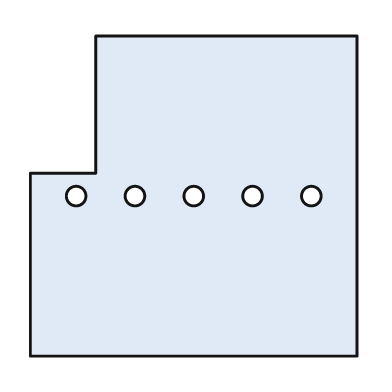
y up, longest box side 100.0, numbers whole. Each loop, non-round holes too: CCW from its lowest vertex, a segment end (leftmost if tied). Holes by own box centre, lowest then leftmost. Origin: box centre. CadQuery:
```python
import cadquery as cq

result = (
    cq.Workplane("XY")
    .moveTo(-50.0, -49.0)
    .lineTo(50.0, -49.0)
    .lineTo(50.0, 49.0)
    .lineTo(-30.0, 49.0)
    .lineTo(-30.0, 7.0)
    .lineTo(-50.0, 7.0)
    .close()
    .moveTo(-36.0, 0.0)
    .circle(3.0)
    .moveTo(-18.0, 0.0)
    .circle(3.0)
    .moveTo(0.0, 0.0)
    .circle(3.0)
    .moveTo(18.0, 0.0)
    .circle(3.0)
    .moveTo(36.0, 0.0)
    .circle(3.0)
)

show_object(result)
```